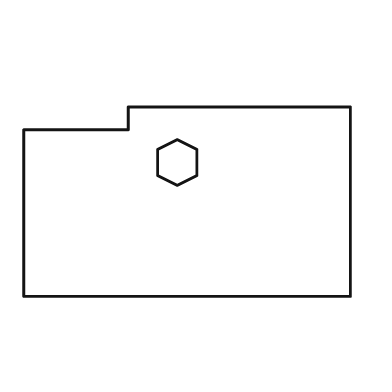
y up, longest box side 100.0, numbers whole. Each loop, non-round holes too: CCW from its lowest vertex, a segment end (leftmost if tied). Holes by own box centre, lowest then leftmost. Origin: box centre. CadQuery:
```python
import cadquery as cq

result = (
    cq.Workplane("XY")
    .moveTo(-50.0, -29.0)
    .lineTo(50.0, -29.0)
    .lineTo(50.0, 29.0)
    .lineTo(-18.0, 29.0)
    .lineTo(-18.0, 22.0)
    .lineTo(-50.0, 22.0)
    .close()
    .moveTo(-3.0, 5.0)
    .lineTo(3.0, 8.0)
    .lineTo(3.0, 16.0)
    .lineTo(-3.0, 19.0)
    .lineTo(-9.0, 16.0)
    .lineTo(-9.0, 8.0)
    .close()
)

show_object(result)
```